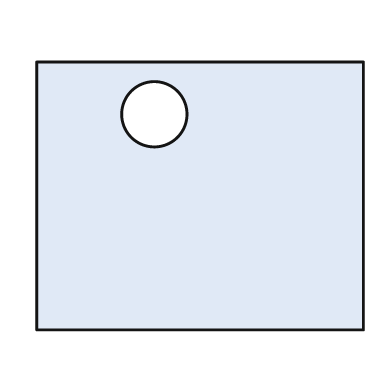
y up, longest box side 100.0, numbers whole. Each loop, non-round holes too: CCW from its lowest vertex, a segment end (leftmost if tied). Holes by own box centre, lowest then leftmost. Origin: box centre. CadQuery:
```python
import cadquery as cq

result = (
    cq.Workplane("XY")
    .moveTo(-50.0, -41.0)
    .lineTo(50.0, -41.0)
    .lineTo(50.0, 41.0)
    .lineTo(-50.0, 41.0)
    .close()
    .moveTo(-14.0, 25.0)
    .circle(10.0)
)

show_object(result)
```